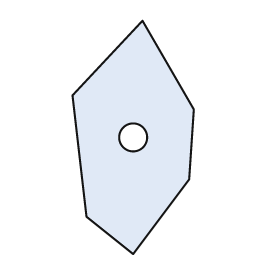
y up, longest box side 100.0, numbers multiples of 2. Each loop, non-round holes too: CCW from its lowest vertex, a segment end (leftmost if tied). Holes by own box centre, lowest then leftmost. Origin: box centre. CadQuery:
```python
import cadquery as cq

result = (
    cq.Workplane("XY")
    .moveTo(0.0, -50.0)
    .lineTo(24.0, -18.0)
    .lineTo(26.0, 12.0)
    .lineTo(4.0, 50.0)
    .lineTo(-26.0, 18.0)
    .lineTo(-20.0, -34.0)
    .close()
    .moveTo(0.0, 0.0)
    .circle(6.0)
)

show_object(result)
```